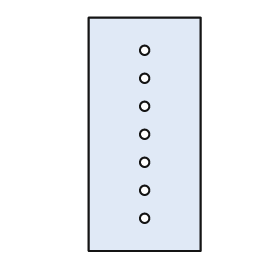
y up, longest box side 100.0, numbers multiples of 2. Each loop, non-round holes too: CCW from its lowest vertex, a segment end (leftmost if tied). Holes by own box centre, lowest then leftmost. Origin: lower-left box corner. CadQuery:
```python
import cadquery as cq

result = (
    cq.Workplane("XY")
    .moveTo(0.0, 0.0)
    .lineTo(48.0, 0.0)
    .lineTo(48.0, 100.0)
    .lineTo(0.0, 100.0)
    .close()
    .moveTo(24.0, 14.0)
    .circle(2.0)
    .moveTo(24.0, 26.0)
    .circle(2.0)
    .moveTo(24.0, 38.0)
    .circle(2.0)
    .moveTo(24.0, 50.0)
    .circle(2.0)
    .moveTo(24.0, 62.0)
    .circle(2.0)
    .moveTo(24.0, 74.0)
    .circle(2.0)
    .moveTo(24.0, 86.0)
    .circle(2.0)
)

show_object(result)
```